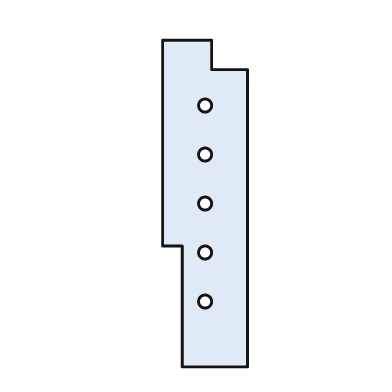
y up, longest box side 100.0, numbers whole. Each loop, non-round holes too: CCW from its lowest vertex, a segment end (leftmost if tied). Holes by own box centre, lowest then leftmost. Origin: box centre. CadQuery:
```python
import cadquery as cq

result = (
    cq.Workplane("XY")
    .moveTo(-7.0, -50.0)
    .lineTo(13.0, -50.0)
    .lineTo(13.0, 41.0)
    .lineTo(2.0, 41.0)
    .lineTo(2.0, 50.0)
    .lineTo(-13.0, 50.0)
    .lineTo(-13.0, -13.0)
    .lineTo(-7.0, -13.0)
    .close()
    .moveTo(0.0, -30.0)
    .circle(2.0)
    .moveTo(0.0, -15.0)
    .circle(2.0)
    .moveTo(0.0, 0.0)
    .circle(2.0)
    .moveTo(0.0, 15.0)
    .circle(2.0)
    .moveTo(0.0, 30.0)
    .circle(2.0)
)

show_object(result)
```